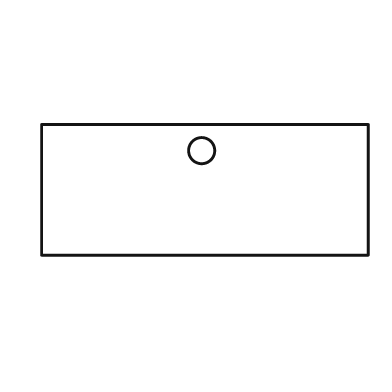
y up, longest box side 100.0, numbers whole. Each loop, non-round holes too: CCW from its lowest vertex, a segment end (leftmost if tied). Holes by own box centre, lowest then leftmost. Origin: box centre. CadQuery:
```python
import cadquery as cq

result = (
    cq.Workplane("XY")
    .moveTo(-50.0, -20.0)
    .lineTo(50.0, -20.0)
    .lineTo(50.0, 20.0)
    .lineTo(-50.0, 20.0)
    .close()
    .moveTo(-1.0, 12.0)
    .circle(4.0)
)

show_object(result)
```